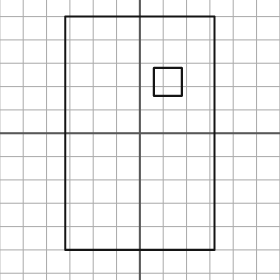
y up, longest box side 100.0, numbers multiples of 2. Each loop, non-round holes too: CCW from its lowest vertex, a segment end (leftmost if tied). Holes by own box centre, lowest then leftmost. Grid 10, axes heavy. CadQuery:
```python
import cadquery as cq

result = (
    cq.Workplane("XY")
    .moveTo(-32.0, -50.0)
    .lineTo(32.0, -50.0)
    .lineTo(32.0, 50.0)
    .lineTo(-32.0, 50.0)
    .close()
    .moveTo(6.0, 16.0)
    .lineTo(18.0, 16.0)
    .lineTo(18.0, 28.0)
    .lineTo(6.0, 28.0)
    .close()
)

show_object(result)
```